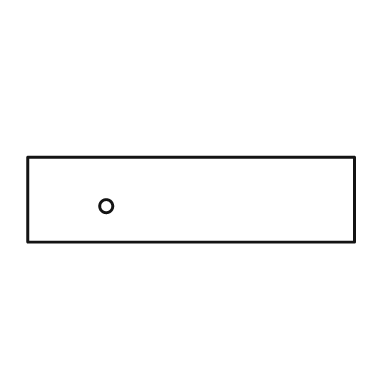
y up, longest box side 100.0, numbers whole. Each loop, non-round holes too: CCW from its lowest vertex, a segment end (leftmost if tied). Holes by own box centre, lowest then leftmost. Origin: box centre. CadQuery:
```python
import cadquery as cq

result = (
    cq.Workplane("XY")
    .moveTo(-50.0, -13.0)
    .lineTo(50.0, -13.0)
    .lineTo(50.0, 13.0)
    .lineTo(-50.0, 13.0)
    .close()
    .moveTo(-26.0, -2.0)
    .circle(2.0)
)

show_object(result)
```